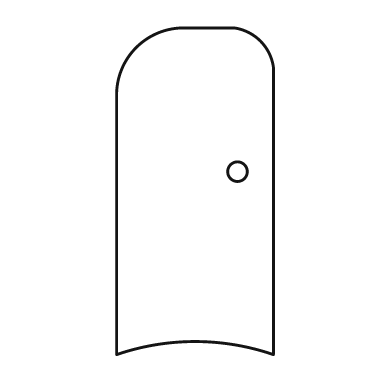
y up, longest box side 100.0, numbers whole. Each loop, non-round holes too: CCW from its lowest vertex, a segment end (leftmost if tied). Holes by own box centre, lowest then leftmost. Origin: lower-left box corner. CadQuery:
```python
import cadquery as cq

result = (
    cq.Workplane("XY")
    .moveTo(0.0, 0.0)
    .threePointArc((24.0, 4.0), (48.0, 0.0))
    .lineTo(48.0, 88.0)
    .threePointArc((44.0, 96.0), (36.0, 100.0))
    .lineTo(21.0, 100.0)
    .threePointArc((6.0, 94.0), (0.0, 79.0))
    .close()
    .moveTo(37.0, 56.0)
    .circle(3.0)
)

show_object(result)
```